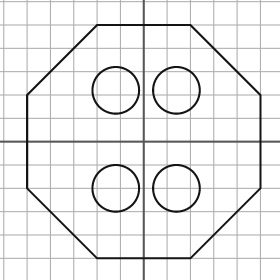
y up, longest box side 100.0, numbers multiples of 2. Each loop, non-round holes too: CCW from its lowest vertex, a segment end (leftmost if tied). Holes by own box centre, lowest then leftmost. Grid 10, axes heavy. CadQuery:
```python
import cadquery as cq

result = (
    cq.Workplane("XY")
    .moveTo(-20.0, -50.0)
    .lineTo(20.0, -50.0)
    .lineTo(50.0, -20.0)
    .lineTo(50.0, 20.0)
    .lineTo(20.0, 50.0)
    .lineTo(-20.0, 50.0)
    .lineTo(-50.0, 20.0)
    .lineTo(-50.0, -20.0)
    .close()
    .moveTo(-12.0, -20.0)
    .circle(10.0)
    .moveTo(14.0, -20.0)
    .circle(10.0)
    .moveTo(-12.0, 22.0)
    .circle(10.0)
    .moveTo(14.0, 22.0)
    .circle(10.0)
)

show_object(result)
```